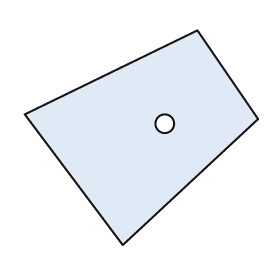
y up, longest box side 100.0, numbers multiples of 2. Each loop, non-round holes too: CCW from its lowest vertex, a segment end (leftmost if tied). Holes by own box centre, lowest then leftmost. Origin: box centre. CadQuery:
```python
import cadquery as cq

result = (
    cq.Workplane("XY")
    .moveTo(-8.0, -46.0)
    .lineTo(50.0, 8.0)
    .lineTo(24.0, 46.0)
    .lineTo(-50.0, 10.0)
    .close()
    .moveTo(10.0, 6.0)
    .circle(4.0)
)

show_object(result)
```